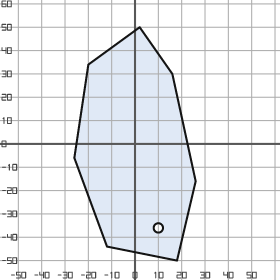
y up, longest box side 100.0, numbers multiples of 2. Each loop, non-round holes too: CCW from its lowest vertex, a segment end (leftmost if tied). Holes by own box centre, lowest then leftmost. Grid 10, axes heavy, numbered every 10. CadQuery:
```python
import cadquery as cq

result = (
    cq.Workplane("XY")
    .moveTo(18.0, -50.0)
    .lineTo(26.0, -16.0)
    .lineTo(16.0, 30.0)
    .lineTo(2.0, 50.0)
    .lineTo(-20.0, 34.0)
    .lineTo(-26.0, -6.0)
    .lineTo(-12.0, -44.0)
    .close()
    .moveTo(10.0, -36.0)
    .circle(2.0)
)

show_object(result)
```